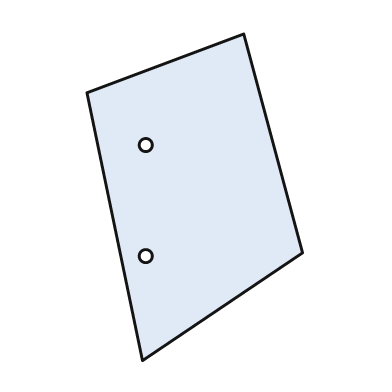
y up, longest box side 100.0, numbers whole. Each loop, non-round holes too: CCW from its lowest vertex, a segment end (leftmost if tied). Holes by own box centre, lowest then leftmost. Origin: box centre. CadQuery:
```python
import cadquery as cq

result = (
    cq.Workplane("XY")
    .moveTo(-16.0, -50.0)
    .lineTo(33.0, -17.0)
    .lineTo(15.0, 50.0)
    .lineTo(-33.0, 32.0)
    .close()
    .moveTo(-15.0, -18.0)
    .circle(2.0)
    .moveTo(-15.0, 16.0)
    .circle(2.0)
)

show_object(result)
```